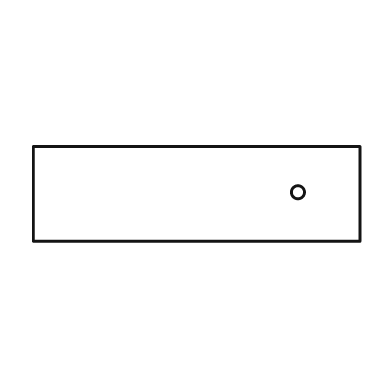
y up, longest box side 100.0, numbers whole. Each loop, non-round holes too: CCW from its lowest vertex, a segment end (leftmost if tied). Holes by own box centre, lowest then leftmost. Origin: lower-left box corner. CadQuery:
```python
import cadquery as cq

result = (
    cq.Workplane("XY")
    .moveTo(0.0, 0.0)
    .lineTo(100.0, 0.0)
    .lineTo(100.0, 29.0)
    .lineTo(0.0, 29.0)
    .close()
    .moveTo(81.0, 15.0)
    .circle(2.0)
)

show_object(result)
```